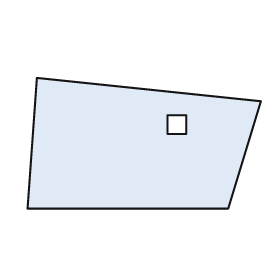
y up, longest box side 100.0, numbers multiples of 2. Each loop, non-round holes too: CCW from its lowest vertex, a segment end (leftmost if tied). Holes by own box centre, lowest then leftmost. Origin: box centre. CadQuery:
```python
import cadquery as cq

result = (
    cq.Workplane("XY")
    .moveTo(-50.0, -28.0)
    .lineTo(36.0, -28.0)
    .lineTo(50.0, 18.0)
    .lineTo(-46.0, 28.0)
    .close()
    .moveTo(10.0, 4.0)
    .lineTo(18.0, 4.0)
    .lineTo(18.0, 12.0)
    .lineTo(10.0, 12.0)
    .close()
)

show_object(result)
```